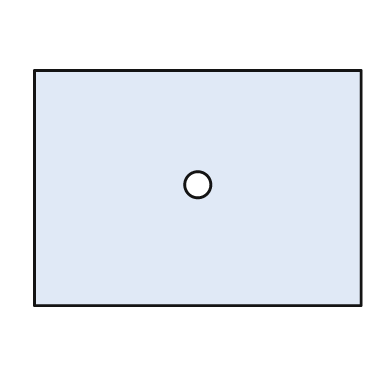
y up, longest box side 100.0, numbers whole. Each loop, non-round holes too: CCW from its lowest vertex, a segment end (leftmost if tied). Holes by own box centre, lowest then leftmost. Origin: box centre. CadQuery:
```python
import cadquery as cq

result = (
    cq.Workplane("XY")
    .moveTo(-50.0, -36.0)
    .lineTo(50.0, -36.0)
    .lineTo(50.0, 36.0)
    .lineTo(-50.0, 36.0)
    .close()
    .moveTo(0.0, 1.0)
    .circle(4.0)
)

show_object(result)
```